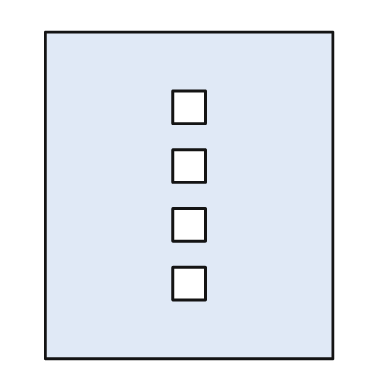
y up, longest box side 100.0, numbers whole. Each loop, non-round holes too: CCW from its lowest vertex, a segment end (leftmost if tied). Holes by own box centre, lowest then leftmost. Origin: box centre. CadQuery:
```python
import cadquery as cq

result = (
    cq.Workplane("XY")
    .moveTo(-44.0, -50.0)
    .lineTo(44.0, -50.0)
    .lineTo(44.0, 50.0)
    .lineTo(-44.0, 50.0)
    .close()
    .moveTo(-5.0, -32.0)
    .lineTo(5.0, -32.0)
    .lineTo(5.0, -22.0)
    .lineTo(-5.0, -22.0)
    .close()
    .moveTo(-5.0, -14.0)
    .lineTo(5.0, -14.0)
    .lineTo(5.0, -4.0)
    .lineTo(-5.0, -4.0)
    .close()
    .moveTo(-5.0, 4.0)
    .lineTo(5.0, 4.0)
    .lineTo(5.0, 14.0)
    .lineTo(-5.0, 14.0)
    .close()
    .moveTo(-5.0, 22.0)
    .lineTo(5.0, 22.0)
    .lineTo(5.0, 32.0)
    .lineTo(-5.0, 32.0)
    .close()
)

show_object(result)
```